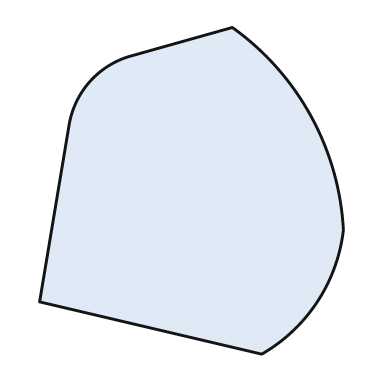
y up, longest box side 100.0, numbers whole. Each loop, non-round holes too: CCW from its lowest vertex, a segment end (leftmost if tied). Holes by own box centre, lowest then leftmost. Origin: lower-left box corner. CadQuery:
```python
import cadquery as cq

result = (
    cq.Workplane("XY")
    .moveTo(68.0, 0.0)
    .threePointArc((85.0, 16.0), (93.0, 38.0))
    .threePointArc((83.0, 73.0), (59.0, 100.0))
    .lineTo(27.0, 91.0)
    .threePointArc((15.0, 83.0), (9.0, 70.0))
    .lineTo(0.0, 16.0)
    .close()
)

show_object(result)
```